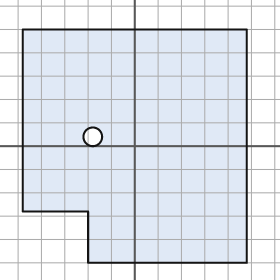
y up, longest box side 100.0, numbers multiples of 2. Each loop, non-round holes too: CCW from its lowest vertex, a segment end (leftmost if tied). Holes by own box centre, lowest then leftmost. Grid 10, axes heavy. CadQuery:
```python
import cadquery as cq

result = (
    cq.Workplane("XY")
    .moveTo(-20.0, -50.0)
    .lineTo(48.0, -50.0)
    .lineTo(48.0, 50.0)
    .lineTo(-48.0, 50.0)
    .lineTo(-48.0, -28.0)
    .lineTo(-20.0, -28.0)
    .close()
    .moveTo(-18.0, 4.0)
    .circle(4.0)
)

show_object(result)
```